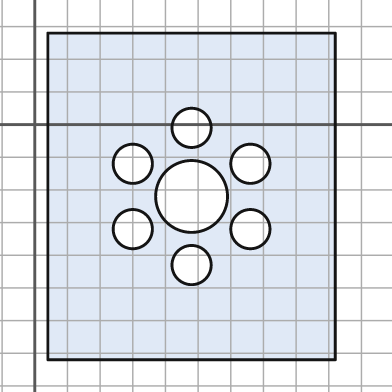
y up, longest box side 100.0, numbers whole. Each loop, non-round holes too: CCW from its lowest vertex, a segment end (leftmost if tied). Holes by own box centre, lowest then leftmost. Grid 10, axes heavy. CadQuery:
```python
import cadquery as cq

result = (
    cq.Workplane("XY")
    .moveTo(4.0, -72.0)
    .lineTo(92.0, -72.0)
    .lineTo(92.0, 28.0)
    .lineTo(4.0, 28.0)
    .close()
    .moveTo(48.0, -43.0)
    .circle(6.0)
    .moveTo(30.0, -32.0)
    .circle(6.0)
    .moveTo(66.0, -32.0)
    .circle(6.0)
    .moveTo(48.0, -22.0)
    .circle(11.0)
    .moveTo(30.0, -12.0)
    .circle(6.0)
    .moveTo(66.0, -12.0)
    .circle(6.0)
    .moveTo(48.0, -1.0)
    .circle(6.0)
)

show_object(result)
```